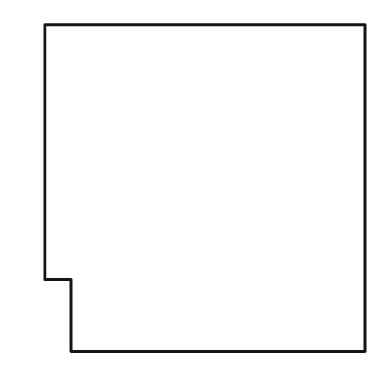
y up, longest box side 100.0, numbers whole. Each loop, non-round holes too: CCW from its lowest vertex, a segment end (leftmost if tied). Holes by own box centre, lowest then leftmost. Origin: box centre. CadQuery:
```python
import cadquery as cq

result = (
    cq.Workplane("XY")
    .moveTo(-41.0, -50.0)
    .lineTo(49.0, -50.0)
    .lineTo(49.0, 50.0)
    .lineTo(-49.0, 50.0)
    .lineTo(-49.0, -28.0)
    .lineTo(-41.0, -28.0)
    .close()
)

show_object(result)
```